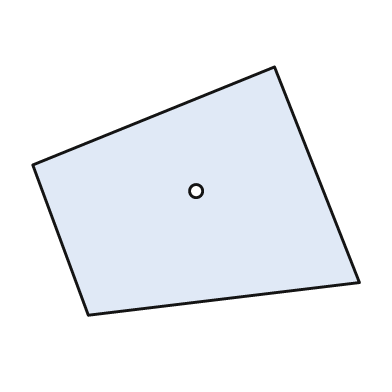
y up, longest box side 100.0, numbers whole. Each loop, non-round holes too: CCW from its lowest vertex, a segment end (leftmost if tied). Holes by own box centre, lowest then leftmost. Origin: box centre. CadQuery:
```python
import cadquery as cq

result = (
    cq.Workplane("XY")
    .moveTo(-33.0, -38.0)
    .lineTo(50.0, -28.0)
    .lineTo(24.0, 38.0)
    .lineTo(-50.0, 8.0)
    .close()
    .moveTo(0.0, 0.0)
    .circle(2.0)
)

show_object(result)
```